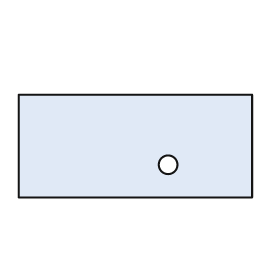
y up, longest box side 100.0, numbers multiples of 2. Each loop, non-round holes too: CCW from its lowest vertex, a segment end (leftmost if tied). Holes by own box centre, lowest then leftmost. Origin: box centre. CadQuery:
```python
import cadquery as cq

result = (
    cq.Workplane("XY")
    .moveTo(-50.0, -22.0)
    .lineTo(50.0, -22.0)
    .lineTo(50.0, 22.0)
    .lineTo(-50.0, 22.0)
    .close()
    .moveTo(14.0, -8.0)
    .circle(4.0)
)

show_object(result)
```